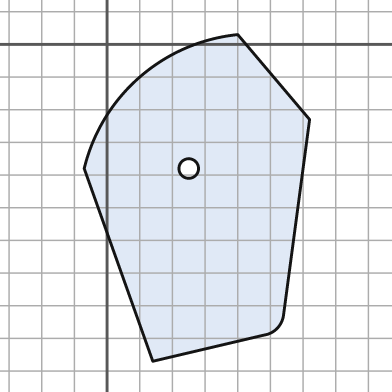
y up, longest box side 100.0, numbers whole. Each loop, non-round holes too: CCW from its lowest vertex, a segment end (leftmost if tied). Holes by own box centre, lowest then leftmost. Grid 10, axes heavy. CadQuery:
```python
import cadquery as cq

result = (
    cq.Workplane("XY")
    .moveTo(14.0, -97.0)
    .lineTo(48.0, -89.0)
    .threePointArc((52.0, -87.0), (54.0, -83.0))
    .lineTo(62.0, -23.0)
    .lineTo(40.0, 3.0)
    .threePointArc((10.0, -10.0), (-7.0, -38.0))
    .close()
    .moveTo(25.0, -38.0)
    .circle(3.0)
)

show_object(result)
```